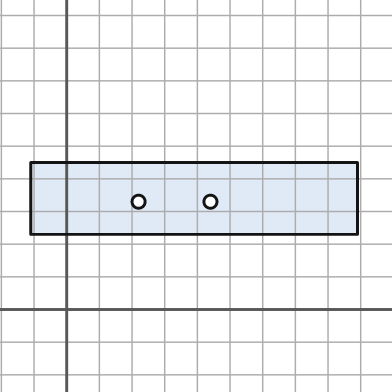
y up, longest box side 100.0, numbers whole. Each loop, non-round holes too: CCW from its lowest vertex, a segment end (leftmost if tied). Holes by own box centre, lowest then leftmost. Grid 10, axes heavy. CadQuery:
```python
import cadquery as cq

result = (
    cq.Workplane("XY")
    .moveTo(-11.0, 23.0)
    .lineTo(89.0, 23.0)
    .lineTo(89.0, 45.0)
    .lineTo(-11.0, 45.0)
    .close()
    .moveTo(22.0, 33.0)
    .circle(2.0)
    .moveTo(44.0, 33.0)
    .circle(2.0)
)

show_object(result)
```